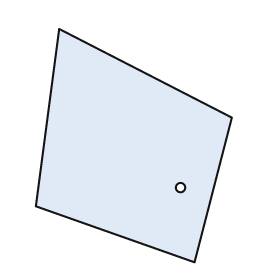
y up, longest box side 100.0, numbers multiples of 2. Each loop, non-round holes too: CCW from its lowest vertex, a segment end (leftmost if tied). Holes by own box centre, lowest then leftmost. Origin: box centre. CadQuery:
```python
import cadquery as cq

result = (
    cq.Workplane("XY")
    .moveTo(26.0, -50.0)
    .lineTo(42.0, 12.0)
    .lineTo(-32.0, 50.0)
    .lineTo(-42.0, -26.0)
    .close()
    .moveTo(20.0, -18.0)
    .circle(2.0)
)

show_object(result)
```